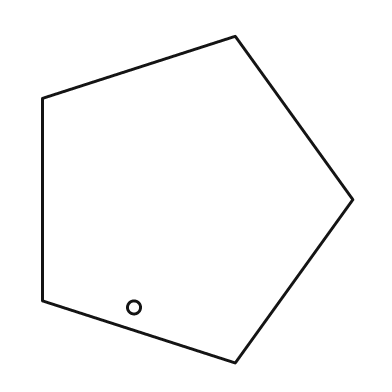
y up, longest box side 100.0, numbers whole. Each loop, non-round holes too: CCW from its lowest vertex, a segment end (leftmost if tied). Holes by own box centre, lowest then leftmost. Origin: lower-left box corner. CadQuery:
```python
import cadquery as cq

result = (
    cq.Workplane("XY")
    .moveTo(59.0, 0.0)
    .lineTo(95.0, 50.0)
    .lineTo(59.0, 100.0)
    .lineTo(0.0, 81.0)
    .lineTo(0.0, 19.0)
    .close()
    .moveTo(28.0, 17.0)
    .circle(2.0)
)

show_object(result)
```